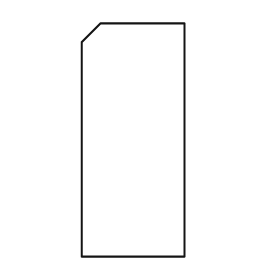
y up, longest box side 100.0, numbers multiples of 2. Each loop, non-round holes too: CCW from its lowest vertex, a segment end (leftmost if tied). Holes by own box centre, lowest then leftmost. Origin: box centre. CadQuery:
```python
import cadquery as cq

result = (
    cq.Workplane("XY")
    .moveTo(-22.0, -50.0)
    .lineTo(22.0, -50.0)
    .lineTo(22.0, 50.0)
    .lineTo(-14.0, 50.0)
    .lineTo(-22.0, 42.0)
    .close()
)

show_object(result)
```